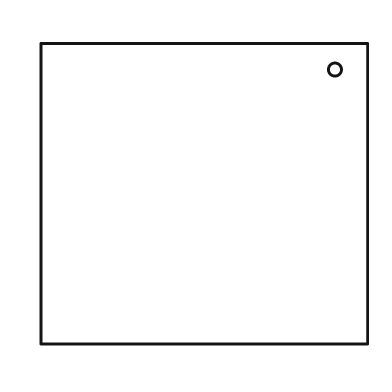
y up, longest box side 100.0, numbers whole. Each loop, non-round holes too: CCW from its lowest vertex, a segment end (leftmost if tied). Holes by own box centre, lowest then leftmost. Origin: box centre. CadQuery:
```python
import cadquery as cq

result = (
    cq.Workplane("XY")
    .moveTo(-50.0, -46.0)
    .lineTo(50.0, -46.0)
    .lineTo(50.0, 46.0)
    .lineTo(-50.0, 46.0)
    .close()
    .moveTo(40.0, 38.0)
    .circle(2.0)
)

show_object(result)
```